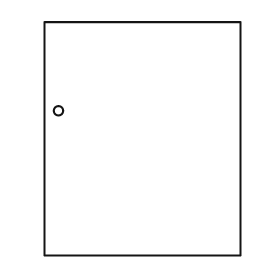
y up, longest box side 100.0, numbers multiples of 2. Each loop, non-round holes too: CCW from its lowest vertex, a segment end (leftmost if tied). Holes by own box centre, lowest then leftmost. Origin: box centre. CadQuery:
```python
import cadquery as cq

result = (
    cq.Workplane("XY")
    .moveTo(-42.0, -50.0)
    .lineTo(42.0, -50.0)
    .lineTo(42.0, 50.0)
    .lineTo(-42.0, 50.0)
    .close()
    .moveTo(-36.0, 12.0)
    .circle(2.0)
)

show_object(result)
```